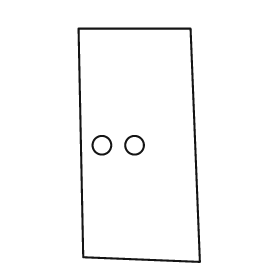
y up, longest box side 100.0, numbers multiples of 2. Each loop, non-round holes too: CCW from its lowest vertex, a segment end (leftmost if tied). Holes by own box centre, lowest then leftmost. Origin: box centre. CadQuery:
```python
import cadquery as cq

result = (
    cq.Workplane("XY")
    .moveTo(26.0, -50.0)
    .lineTo(22.0, 50.0)
    .lineTo(-26.0, 50.0)
    .lineTo(-24.0, -48.0)
    .close()
    .moveTo(-16.0, 0.0)
    .circle(4.0)
    .moveTo(-2.0, 0.0)
    .circle(4.0)
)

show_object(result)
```